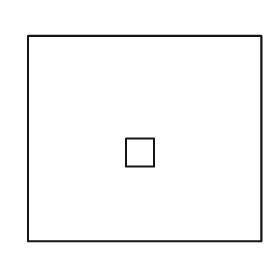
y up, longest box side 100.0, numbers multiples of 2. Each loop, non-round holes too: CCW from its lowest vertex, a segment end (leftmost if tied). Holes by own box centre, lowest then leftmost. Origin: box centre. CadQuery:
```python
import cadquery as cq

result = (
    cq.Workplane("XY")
    .moveTo(-50.0, -44.0)
    .lineTo(50.0, -44.0)
    .lineTo(50.0, 44.0)
    .lineTo(-50.0, 44.0)
    .close()
    .moveTo(-8.0, -12.0)
    .lineTo(4.0, -12.0)
    .lineTo(4.0, 0.0)
    .lineTo(-8.0, 0.0)
    .close()
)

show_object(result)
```